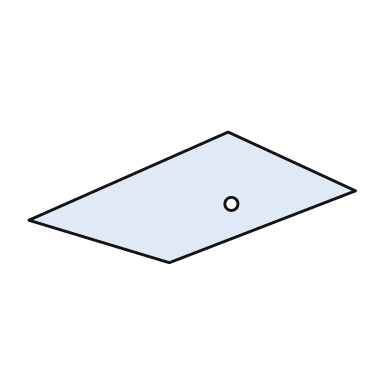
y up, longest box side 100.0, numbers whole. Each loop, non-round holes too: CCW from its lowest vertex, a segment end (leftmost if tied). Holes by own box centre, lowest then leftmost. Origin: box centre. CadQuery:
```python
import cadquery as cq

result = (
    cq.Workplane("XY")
    .moveTo(-7.0, -20.0)
    .lineTo(50.0, 2.0)
    .lineTo(11.0, 20.0)
    .lineTo(-50.0, -7.0)
    .close()
    .moveTo(12.0, -2.0)
    .circle(2.0)
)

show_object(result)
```